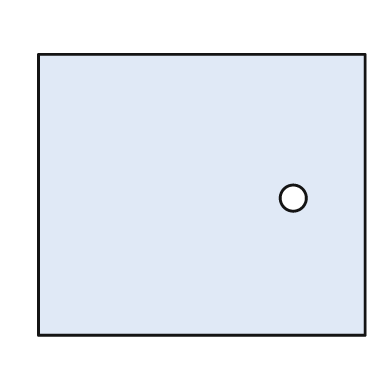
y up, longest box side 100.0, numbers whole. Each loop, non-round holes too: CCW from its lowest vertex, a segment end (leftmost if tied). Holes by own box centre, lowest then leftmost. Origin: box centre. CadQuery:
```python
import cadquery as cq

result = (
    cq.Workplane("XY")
    .moveTo(-50.0, -43.0)
    .lineTo(50.0, -43.0)
    .lineTo(50.0, 43.0)
    .lineTo(-50.0, 43.0)
    .close()
    .moveTo(28.0, -1.0)
    .circle(4.0)
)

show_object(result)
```